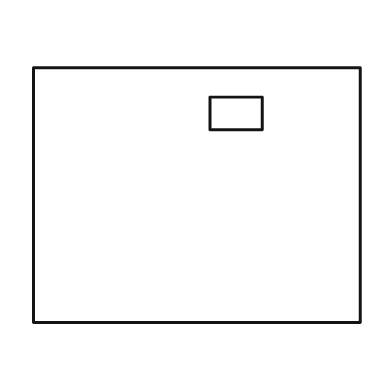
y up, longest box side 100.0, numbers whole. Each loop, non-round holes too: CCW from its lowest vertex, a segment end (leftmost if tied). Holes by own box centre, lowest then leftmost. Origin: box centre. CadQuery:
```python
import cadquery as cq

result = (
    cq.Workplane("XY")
    .moveTo(-50.0, -39.0)
    .lineTo(50.0, -39.0)
    .lineTo(50.0, 39.0)
    .lineTo(-50.0, 39.0)
    .close()
    .moveTo(4.0, 20.0)
    .lineTo(20.0, 20.0)
    .lineTo(20.0, 30.0)
    .lineTo(4.0, 30.0)
    .close()
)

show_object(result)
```